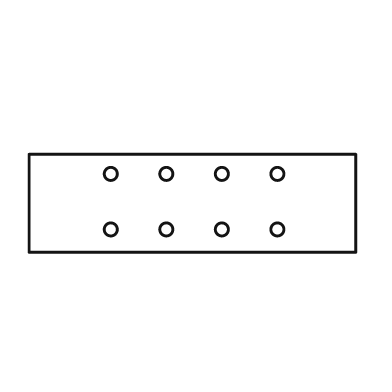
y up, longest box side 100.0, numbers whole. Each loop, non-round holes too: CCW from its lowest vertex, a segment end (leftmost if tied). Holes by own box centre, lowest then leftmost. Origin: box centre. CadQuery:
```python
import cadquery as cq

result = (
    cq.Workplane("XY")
    .moveTo(-50.0, -15.0)
    .lineTo(50.0, -15.0)
    .lineTo(50.0, 15.0)
    .lineTo(-50.0, 15.0)
    .close()
    .moveTo(-25.0, -8.0)
    .circle(2.0)
    .moveTo(-8.0, -8.0)
    .circle(2.0)
    .moveTo(9.0, -8.0)
    .circle(2.0)
    .moveTo(26.0, -8.0)
    .circle(2.0)
    .moveTo(-25.0, 9.0)
    .circle(2.0)
    .moveTo(-8.0, 9.0)
    .circle(2.0)
    .moveTo(9.0, 9.0)
    .circle(2.0)
    .moveTo(26.0, 9.0)
    .circle(2.0)
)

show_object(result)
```